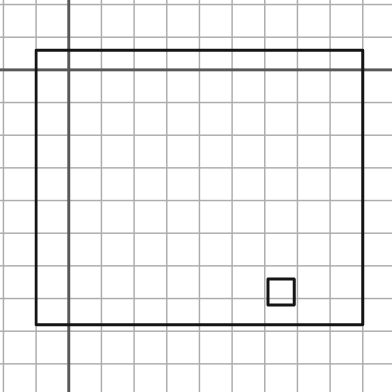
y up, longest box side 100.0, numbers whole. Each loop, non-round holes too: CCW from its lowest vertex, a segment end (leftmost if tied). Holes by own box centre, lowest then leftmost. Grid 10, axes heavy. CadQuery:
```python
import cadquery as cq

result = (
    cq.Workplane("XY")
    .moveTo(-10.0, -78.0)
    .lineTo(90.0, -78.0)
    .lineTo(90.0, 6.0)
    .lineTo(-10.0, 6.0)
    .close()
    .moveTo(61.0, -72.0)
    .lineTo(69.0, -72.0)
    .lineTo(69.0, -64.0)
    .lineTo(61.0, -64.0)
    .close()
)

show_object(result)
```